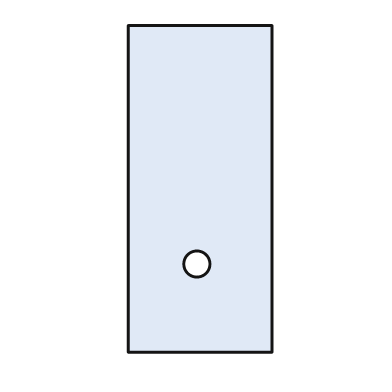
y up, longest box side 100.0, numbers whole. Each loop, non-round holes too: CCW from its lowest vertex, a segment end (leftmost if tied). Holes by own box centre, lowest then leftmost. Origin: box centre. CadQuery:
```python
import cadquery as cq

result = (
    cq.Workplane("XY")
    .moveTo(-22.0, -50.0)
    .lineTo(22.0, -50.0)
    .lineTo(22.0, 50.0)
    .lineTo(-22.0, 50.0)
    .close()
    .moveTo(-1.0, -23.0)
    .circle(4.0)
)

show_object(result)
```